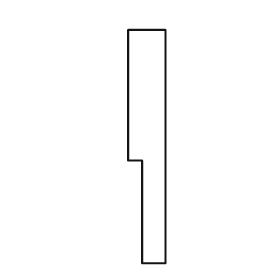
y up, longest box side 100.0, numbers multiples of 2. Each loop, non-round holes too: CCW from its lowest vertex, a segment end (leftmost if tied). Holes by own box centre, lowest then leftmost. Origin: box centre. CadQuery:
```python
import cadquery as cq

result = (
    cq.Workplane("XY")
    .moveTo(-2.0, -50.0)
    .lineTo(8.0, -50.0)
    .lineTo(8.0, 50.0)
    .lineTo(-8.0, 50.0)
    .lineTo(-8.0, -6.0)
    .lineTo(-2.0, -6.0)
    .close()
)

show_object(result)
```